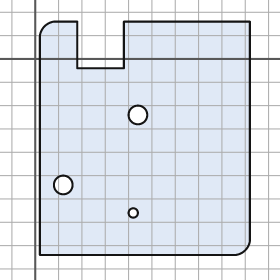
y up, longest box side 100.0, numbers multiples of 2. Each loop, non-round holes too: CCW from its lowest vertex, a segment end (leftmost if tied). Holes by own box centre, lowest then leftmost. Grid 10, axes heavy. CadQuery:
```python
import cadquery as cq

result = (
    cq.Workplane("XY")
    .moveTo(2.0, -84.0)
    .lineTo(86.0, -84.0)
    .threePointArc((90.0, -82.0), (92.0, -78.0))
    .lineTo(92.0, 16.0)
    .lineTo(38.0, 16.0)
    .lineTo(38.0, -4.0)
    .lineTo(18.0, -4.0)
    .lineTo(18.0, 16.0)
    .lineTo(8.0, 16.0)
    .threePointArc((4.0, 14.0), (2.0, 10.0))
    .close()
    .moveTo(42.0, -66.0)
    .circle(2.0)
    .moveTo(12.0, -54.0)
    .circle(4.0)
    .moveTo(44.0, -24.0)
    .circle(4.0)
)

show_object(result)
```